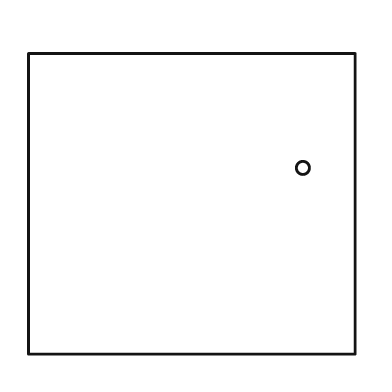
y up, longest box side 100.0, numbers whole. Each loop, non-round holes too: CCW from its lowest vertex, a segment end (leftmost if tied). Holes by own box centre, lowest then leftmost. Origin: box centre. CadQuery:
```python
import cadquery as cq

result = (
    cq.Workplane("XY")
    .moveTo(-50.0, -46.0)
    .lineTo(50.0, -46.0)
    .lineTo(50.0, 46.0)
    .lineTo(-50.0, 46.0)
    .close()
    .moveTo(34.0, 11.0)
    .circle(2.0)
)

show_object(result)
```